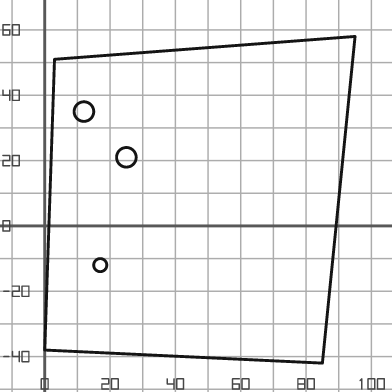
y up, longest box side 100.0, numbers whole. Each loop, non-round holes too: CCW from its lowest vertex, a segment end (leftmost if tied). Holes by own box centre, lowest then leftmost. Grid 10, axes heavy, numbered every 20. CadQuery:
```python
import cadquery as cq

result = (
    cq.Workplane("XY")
    .moveTo(85.0, -42.0)
    .lineTo(95.0, 58.0)
    .lineTo(3.0, 51.0)
    .lineTo(0.0, -38.0)
    .close()
    .moveTo(17.0, -12.0)
    .circle(2.0)
    .moveTo(25.0, 21.0)
    .circle(3.0)
    .moveTo(12.0, 35.0)
    .circle(3.0)
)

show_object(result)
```